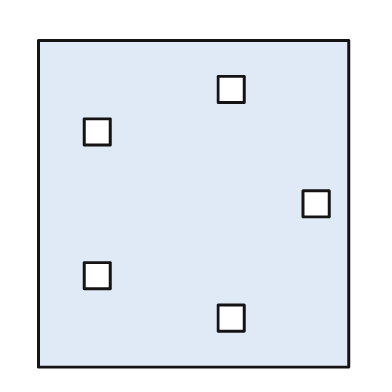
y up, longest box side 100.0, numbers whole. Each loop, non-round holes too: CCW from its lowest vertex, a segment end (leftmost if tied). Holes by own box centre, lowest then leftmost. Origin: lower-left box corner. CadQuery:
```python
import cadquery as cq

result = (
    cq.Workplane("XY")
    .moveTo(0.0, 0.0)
    .lineTo(95.0, 0.0)
    .lineTo(95.0, 100.0)
    .lineTo(0.0, 100.0)
    .close()
    .moveTo(55.0, 11.0)
    .lineTo(63.0, 11.0)
    .lineTo(63.0, 19.0)
    .lineTo(55.0, 19.0)
    .close()
    .moveTo(14.0, 24.0)
    .lineTo(22.0, 24.0)
    .lineTo(22.0, 32.0)
    .lineTo(14.0, 32.0)
    .close()
    .moveTo(81.0, 46.0)
    .lineTo(89.0, 46.0)
    .lineTo(89.0, 54.0)
    .lineTo(81.0, 54.0)
    .close()
    .moveTo(14.0, 68.0)
    .lineTo(22.0, 68.0)
    .lineTo(22.0, 76.0)
    .lineTo(14.0, 76.0)
    .close()
    .moveTo(55.0, 81.0)
    .lineTo(63.0, 81.0)
    .lineTo(63.0, 89.0)
    .lineTo(55.0, 89.0)
    .close()
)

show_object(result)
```